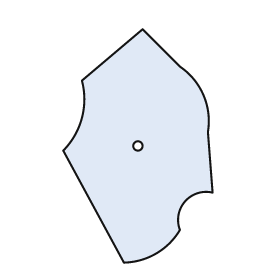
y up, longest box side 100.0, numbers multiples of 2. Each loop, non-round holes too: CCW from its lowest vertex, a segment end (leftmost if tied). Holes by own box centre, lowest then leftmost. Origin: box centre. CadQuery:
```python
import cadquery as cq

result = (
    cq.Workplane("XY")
    .moveTo(-6.0, -50.0)
    .threePointArc((8.0, -46.0), (18.0, -36.0))
    .threePointArc((20.0, -24.0), (32.0, -20.0))
    .lineTo(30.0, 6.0)
    .threePointArc((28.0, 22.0), (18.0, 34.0))
    .lineTo(2.0, 50.0)
    .lineTo(-24.0, 28.0)
    .threePointArc((-24.0, 12.0), (-32.0, -2.0))
    .close()
    .moveTo(0.0, 0.0)
    .circle(2.0)
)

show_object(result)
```